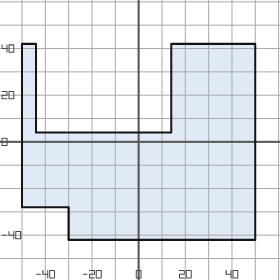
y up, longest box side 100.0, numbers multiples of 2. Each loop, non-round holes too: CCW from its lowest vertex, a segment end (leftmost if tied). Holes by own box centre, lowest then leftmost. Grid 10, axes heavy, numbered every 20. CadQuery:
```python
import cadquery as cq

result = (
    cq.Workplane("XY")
    .moveTo(-30.0, -42.0)
    .lineTo(50.0, -42.0)
    .lineTo(50.0, 42.0)
    .lineTo(14.0, 42.0)
    .lineTo(14.0, 4.0)
    .lineTo(-44.0, 4.0)
    .lineTo(-44.0, 42.0)
    .lineTo(-50.0, 42.0)
    .lineTo(-50.0, -28.0)
    .lineTo(-30.0, -28.0)
    .close()
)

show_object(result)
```